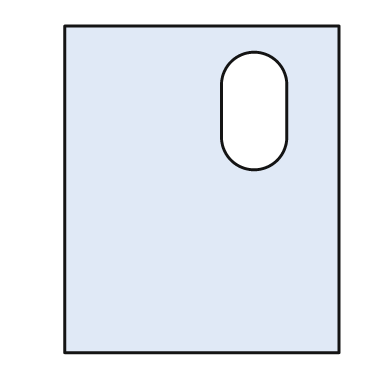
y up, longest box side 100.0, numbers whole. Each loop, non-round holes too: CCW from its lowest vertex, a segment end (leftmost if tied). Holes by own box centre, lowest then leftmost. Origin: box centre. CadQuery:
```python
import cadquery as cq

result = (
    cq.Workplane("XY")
    .moveTo(-42.0, -50.0)
    .lineTo(42.0, -50.0)
    .lineTo(42.0, 50.0)
    .lineTo(-42.0, 50.0)
    .close()
    .moveTo(6.0, 16.0)
    .threePointArc((16.0, 6.0), (26.0, 16.0))
    .lineTo(26.0, 32.0)
    .threePointArc((16.0, 42.0), (6.0, 32.0))
    .close()
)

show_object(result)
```